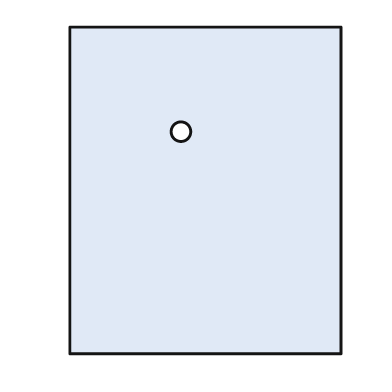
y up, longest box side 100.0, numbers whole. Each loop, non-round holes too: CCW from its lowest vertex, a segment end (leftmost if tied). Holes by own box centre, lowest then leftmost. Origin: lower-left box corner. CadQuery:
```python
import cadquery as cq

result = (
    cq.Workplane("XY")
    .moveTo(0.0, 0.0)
    .lineTo(83.0, 0.0)
    .lineTo(83.0, 100.0)
    .lineTo(0.0, 100.0)
    .close()
    .moveTo(34.0, 68.0)
    .circle(3.0)
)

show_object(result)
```